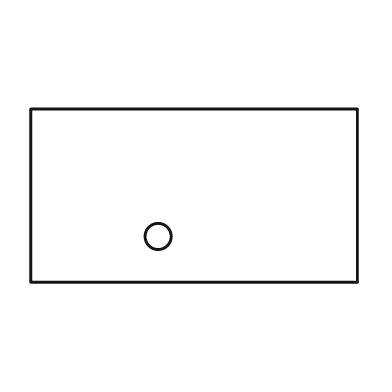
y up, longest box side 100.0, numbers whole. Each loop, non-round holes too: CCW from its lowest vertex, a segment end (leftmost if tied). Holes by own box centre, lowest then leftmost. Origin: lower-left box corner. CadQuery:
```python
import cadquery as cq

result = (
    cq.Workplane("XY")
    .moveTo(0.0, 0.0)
    .lineTo(100.0, 0.0)
    .lineTo(100.0, 53.0)
    .lineTo(0.0, 53.0)
    .close()
    .moveTo(39.0, 14.0)
    .circle(4.0)
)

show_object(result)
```